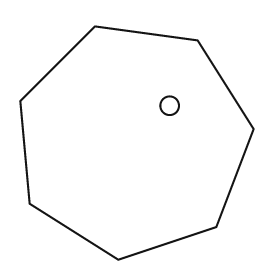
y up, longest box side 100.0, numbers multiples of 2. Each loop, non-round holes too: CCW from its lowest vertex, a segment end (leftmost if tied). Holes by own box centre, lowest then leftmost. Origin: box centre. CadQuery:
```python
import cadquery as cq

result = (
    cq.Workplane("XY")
    .moveTo(-8.0, -50.0)
    .lineTo(34.0, -36.0)
    .lineTo(50.0, 6.0)
    .lineTo(26.0, 44.0)
    .lineTo(-18.0, 50.0)
    .lineTo(-50.0, 18.0)
    .lineTo(-46.0, -26.0)
    .close()
    .moveTo(14.0, 16.0)
    .circle(4.0)
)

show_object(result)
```